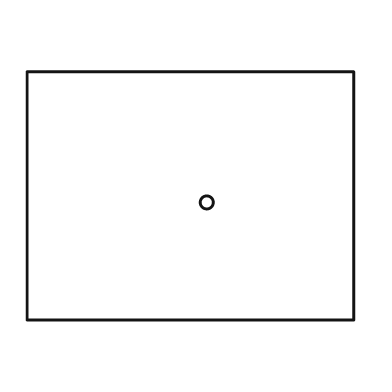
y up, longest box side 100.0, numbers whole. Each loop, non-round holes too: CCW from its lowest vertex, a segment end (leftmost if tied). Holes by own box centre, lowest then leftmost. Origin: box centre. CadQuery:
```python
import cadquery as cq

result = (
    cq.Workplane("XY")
    .moveTo(-50.0, -38.0)
    .lineTo(50.0, -38.0)
    .lineTo(50.0, 38.0)
    .lineTo(-50.0, 38.0)
    .close()
    .moveTo(5.0, -2.0)
    .circle(2.0)
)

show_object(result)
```